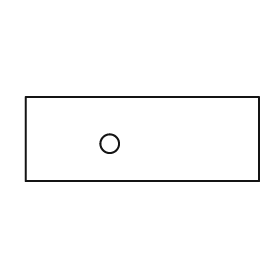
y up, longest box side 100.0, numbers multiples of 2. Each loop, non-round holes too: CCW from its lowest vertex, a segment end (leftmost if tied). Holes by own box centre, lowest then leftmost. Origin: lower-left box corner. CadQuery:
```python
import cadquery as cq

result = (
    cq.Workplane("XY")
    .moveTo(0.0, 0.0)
    .lineTo(100.0, 0.0)
    .lineTo(100.0, 36.0)
    .lineTo(0.0, 36.0)
    .close()
    .moveTo(36.0, 16.0)
    .circle(4.0)
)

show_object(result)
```